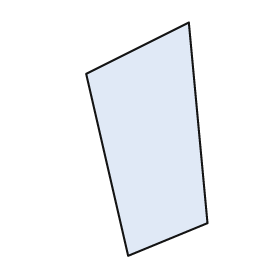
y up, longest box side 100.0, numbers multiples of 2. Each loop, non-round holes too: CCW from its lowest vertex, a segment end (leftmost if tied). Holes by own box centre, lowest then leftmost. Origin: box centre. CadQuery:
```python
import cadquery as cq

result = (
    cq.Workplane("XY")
    .moveTo(-8.0, -50.0)
    .lineTo(26.0, -36.0)
    .lineTo(18.0, 50.0)
    .lineTo(-26.0, 28.0)
    .close()
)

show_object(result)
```